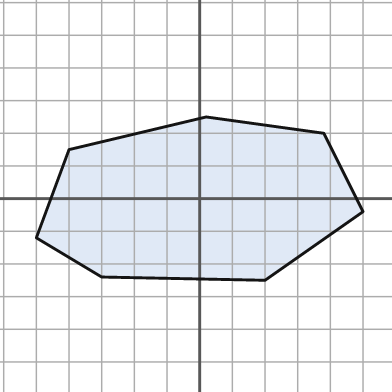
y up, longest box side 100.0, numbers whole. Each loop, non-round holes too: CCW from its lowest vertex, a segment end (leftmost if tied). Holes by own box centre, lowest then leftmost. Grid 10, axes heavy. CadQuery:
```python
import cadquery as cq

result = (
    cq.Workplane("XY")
    .moveTo(20.0, -25.0)
    .lineTo(50.0, -4.0)
    .lineTo(38.0, 20.0)
    .lineTo(2.0, 25.0)
    .lineTo(-40.0, 15.0)
    .lineTo(-50.0, -12.0)
    .lineTo(-30.0, -24.0)
    .close()
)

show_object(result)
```